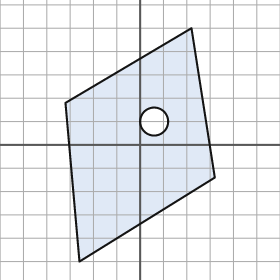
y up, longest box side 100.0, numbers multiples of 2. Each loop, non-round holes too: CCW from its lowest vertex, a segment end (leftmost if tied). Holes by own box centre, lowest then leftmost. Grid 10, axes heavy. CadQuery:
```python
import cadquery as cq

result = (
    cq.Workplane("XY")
    .moveTo(-26.0, -50.0)
    .lineTo(32.0, -14.0)
    .lineTo(22.0, 50.0)
    .lineTo(-32.0, 18.0)
    .close()
    .moveTo(6.0, 10.0)
    .circle(6.0)
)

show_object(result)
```